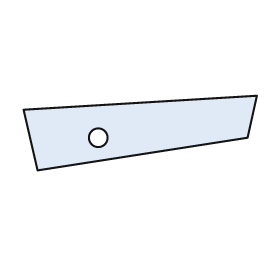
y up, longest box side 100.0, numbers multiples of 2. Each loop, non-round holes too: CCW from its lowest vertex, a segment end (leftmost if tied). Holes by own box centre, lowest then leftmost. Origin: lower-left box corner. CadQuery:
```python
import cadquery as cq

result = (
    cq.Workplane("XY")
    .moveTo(6.0, 0.0)
    .lineTo(96.0, 14.0)
    .lineTo(100.0, 32.0)
    .lineTo(0.0, 26.0)
    .close()
    .moveTo(32.0, 14.0)
    .circle(4.0)
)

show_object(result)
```